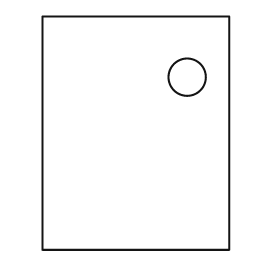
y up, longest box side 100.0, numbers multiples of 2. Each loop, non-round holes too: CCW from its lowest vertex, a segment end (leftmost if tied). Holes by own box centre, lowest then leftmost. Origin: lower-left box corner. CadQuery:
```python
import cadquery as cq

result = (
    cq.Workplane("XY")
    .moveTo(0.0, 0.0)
    .lineTo(80.0, 0.0)
    .lineTo(80.0, 100.0)
    .lineTo(0.0, 100.0)
    .close()
    .moveTo(62.0, 74.0)
    .circle(8.0)
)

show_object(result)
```